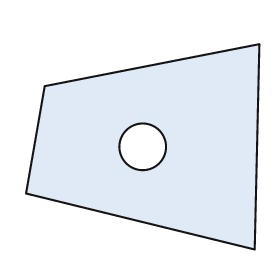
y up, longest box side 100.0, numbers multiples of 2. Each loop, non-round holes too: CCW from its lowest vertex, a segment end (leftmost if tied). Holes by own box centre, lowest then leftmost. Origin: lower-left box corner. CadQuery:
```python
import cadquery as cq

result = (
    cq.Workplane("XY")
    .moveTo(98.0, 0.0)
    .lineTo(100.0, 88.0)
    .lineTo(8.0, 70.0)
    .lineTo(0.0, 24.0)
    .close()
    .moveTo(50.0, 44.0)
    .circle(10.0)
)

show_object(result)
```